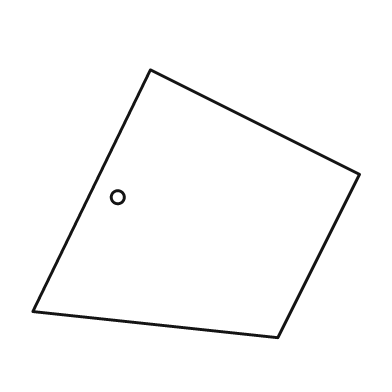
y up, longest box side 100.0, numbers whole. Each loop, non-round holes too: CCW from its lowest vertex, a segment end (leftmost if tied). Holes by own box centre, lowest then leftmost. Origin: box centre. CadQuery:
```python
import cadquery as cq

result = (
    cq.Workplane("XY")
    .moveTo(25.0, -41.0)
    .lineTo(50.0, 9.0)
    .lineTo(-14.0, 41.0)
    .lineTo(-50.0, -33.0)
    .close()
    .moveTo(-24.0, 2.0)
    .circle(2.0)
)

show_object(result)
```